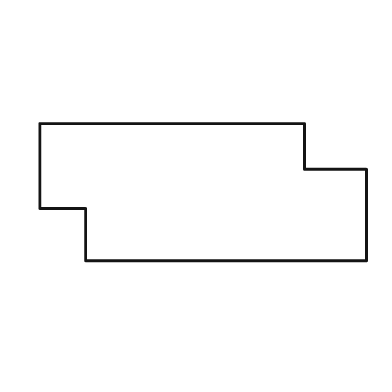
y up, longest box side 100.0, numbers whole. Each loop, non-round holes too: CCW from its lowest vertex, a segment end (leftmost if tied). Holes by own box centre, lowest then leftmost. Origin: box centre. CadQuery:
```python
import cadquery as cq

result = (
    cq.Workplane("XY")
    .moveTo(-36.0, -21.0)
    .lineTo(50.0, -21.0)
    .lineTo(50.0, 7.0)
    .lineTo(31.0, 7.0)
    .lineTo(31.0, 21.0)
    .lineTo(-50.0, 21.0)
    .lineTo(-50.0, -5.0)
    .lineTo(-36.0, -5.0)
    .close()
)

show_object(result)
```